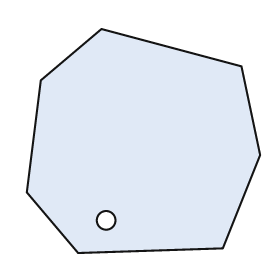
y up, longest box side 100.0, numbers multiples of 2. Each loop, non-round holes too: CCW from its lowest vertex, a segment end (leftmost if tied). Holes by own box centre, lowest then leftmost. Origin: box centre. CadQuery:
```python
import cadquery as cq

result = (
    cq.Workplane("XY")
    .moveTo(-28.0, -48.0)
    .lineTo(34.0, -46.0)
    .lineTo(50.0, -6.0)
    .lineTo(42.0, 32.0)
    .lineTo(-18.0, 48.0)
    .lineTo(-44.0, 26.0)
    .lineTo(-50.0, -22.0)
    .close()
    .moveTo(-16.0, -34.0)
    .circle(4.0)
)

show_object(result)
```